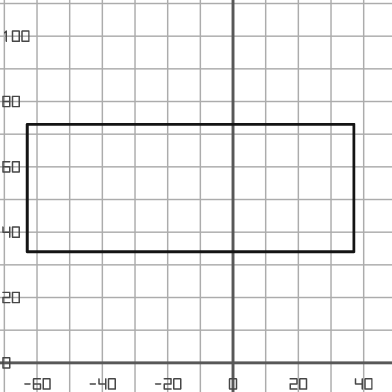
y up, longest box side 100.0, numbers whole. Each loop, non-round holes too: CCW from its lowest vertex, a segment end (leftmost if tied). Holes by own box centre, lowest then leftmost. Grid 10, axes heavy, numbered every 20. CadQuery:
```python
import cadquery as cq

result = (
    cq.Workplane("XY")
    .moveTo(-63.0, 34.0)
    .lineTo(37.0, 34.0)
    .lineTo(37.0, 73.0)
    .lineTo(-63.0, 73.0)
    .close()
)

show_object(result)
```